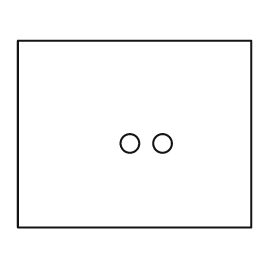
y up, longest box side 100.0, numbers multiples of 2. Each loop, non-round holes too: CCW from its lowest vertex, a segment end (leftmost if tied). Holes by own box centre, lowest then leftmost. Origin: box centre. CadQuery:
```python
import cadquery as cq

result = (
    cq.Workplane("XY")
    .moveTo(-50.0, -40.0)
    .lineTo(50.0, -40.0)
    .lineTo(50.0, 40.0)
    .lineTo(-50.0, 40.0)
    .close()
    .moveTo(-2.0, -4.0)
    .circle(4.0)
    .moveTo(12.0, -4.0)
    .circle(4.0)
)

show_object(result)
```